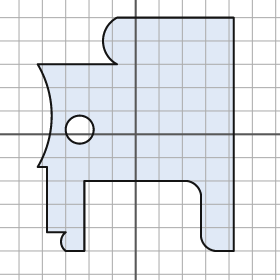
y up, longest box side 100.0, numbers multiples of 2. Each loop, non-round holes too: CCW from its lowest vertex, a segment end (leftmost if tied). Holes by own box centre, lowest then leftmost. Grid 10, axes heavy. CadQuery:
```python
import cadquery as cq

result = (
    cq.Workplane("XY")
    .moveTo(-30.0, -50.0)
    .lineTo(-22.0, -50.0)
    .lineTo(-22.0, -20.0)
    .lineTo(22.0, -20.0)
    .threePointArc((26.0, -22.0), (28.0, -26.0))
    .lineTo(28.0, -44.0)
    .threePointArc((30.0, -48.0), (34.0, -50.0))
    .lineTo(42.0, -50.0)
    .lineTo(42.0, 50.0)
    .lineTo(-8.0, 50.0)
    .threePointArc((-14.0, 40.0), (-8.0, 30.0))
    .lineTo(-42.0, 30.0)
    .threePointArc((-36.0, 8.0), (-42.0, -14.0))
    .lineTo(-38.0, -14.0)
    .lineTo(-38.0, -42.0)
    .lineTo(-30.0, -42.0)
    .threePointArc((-32.0, -46.0), (-30.0, -50.0))
    .close()
    .moveTo(-24.0, 2.0)
    .circle(6.0)
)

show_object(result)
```